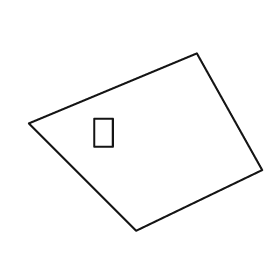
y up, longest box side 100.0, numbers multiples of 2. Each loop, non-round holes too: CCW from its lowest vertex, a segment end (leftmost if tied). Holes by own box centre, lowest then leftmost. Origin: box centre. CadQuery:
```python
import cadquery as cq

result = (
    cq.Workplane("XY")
    .moveTo(-4.0, -38.0)
    .lineTo(50.0, -12.0)
    .lineTo(22.0, 38.0)
    .lineTo(-50.0, 8.0)
    .close()
    .moveTo(-22.0, -2.0)
    .lineTo(-14.0, -2.0)
    .lineTo(-14.0, 10.0)
    .lineTo(-22.0, 10.0)
    .close()
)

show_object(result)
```